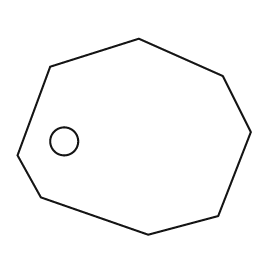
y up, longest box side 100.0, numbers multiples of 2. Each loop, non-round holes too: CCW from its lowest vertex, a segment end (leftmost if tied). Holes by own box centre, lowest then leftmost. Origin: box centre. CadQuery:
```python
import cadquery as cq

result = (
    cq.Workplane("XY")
    .moveTo(6.0, -42.0)
    .lineTo(36.0, -34.0)
    .lineTo(50.0, 2.0)
    .lineTo(38.0, 26.0)
    .lineTo(2.0, 42.0)
    .lineTo(-36.0, 30.0)
    .lineTo(-50.0, -8.0)
    .lineTo(-40.0, -26.0)
    .close()
    .moveTo(-30.0, -2.0)
    .circle(6.0)
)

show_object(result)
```